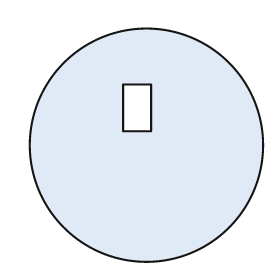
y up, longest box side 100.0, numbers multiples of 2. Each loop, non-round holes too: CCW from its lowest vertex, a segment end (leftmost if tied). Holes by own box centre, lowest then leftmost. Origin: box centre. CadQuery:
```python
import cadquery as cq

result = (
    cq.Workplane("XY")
    .moveTo(0.0, 0.0)
    .circle(50.0)
    .moveTo(-10.0, 6.0)
    .lineTo(2.0, 6.0)
    .lineTo(2.0, 26.0)
    .lineTo(-10.0, 26.0)
    .close()
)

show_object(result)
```